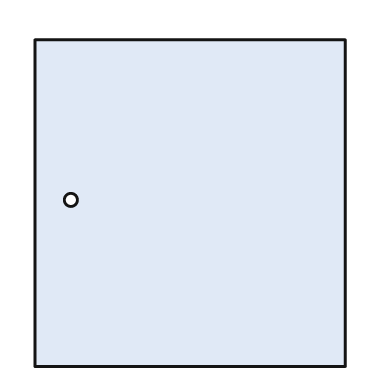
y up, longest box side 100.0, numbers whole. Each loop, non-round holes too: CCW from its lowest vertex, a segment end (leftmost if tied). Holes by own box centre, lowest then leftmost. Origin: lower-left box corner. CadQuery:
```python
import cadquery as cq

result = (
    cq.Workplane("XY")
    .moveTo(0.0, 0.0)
    .lineTo(95.0, 0.0)
    .lineTo(95.0, 100.0)
    .lineTo(0.0, 100.0)
    .close()
    .moveTo(11.0, 51.0)
    .circle(2.0)
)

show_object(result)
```